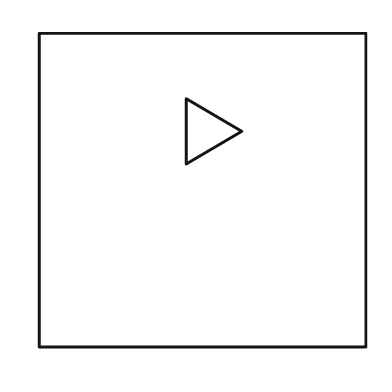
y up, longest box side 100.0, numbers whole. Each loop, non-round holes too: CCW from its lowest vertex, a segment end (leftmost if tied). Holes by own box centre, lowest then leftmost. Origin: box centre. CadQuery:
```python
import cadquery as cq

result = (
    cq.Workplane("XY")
    .moveTo(-50.0, -48.0)
    .lineTo(50.0, -48.0)
    .lineTo(50.0, 48.0)
    .lineTo(-50.0, 48.0)
    .close()
    .moveTo(-5.0, 8.0)
    .lineTo(12.0, 18.0)
    .lineTo(-5.0, 28.0)
    .close()
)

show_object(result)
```